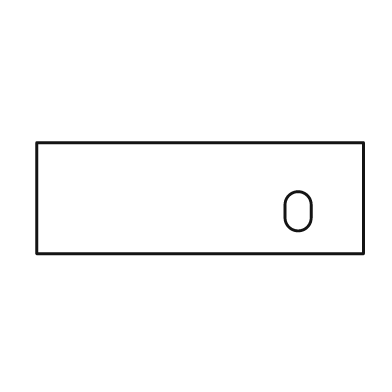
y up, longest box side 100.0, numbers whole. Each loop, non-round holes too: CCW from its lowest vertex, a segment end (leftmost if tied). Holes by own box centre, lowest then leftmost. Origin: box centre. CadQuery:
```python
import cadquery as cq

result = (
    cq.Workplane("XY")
    .moveTo(-50.0, -17.0)
    .lineTo(50.0, -17.0)
    .lineTo(50.0, 17.0)
    .lineTo(-50.0, 17.0)
    .close()
    .moveTo(26.0, -6.0)
    .threePointArc((30.0, -10.0), (34.0, -6.0))
    .lineTo(34.0, -2.0)
    .threePointArc((30.0, 2.0), (26.0, -2.0))
    .close()
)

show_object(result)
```